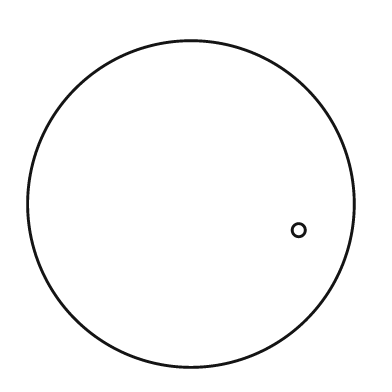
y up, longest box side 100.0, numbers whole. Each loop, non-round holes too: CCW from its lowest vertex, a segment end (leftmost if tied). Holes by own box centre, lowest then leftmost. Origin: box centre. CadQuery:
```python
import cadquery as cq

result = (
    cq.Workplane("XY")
    .moveTo(0.0, 0.0)
    .circle(50.0)
    .moveTo(33.0, -8.0)
    .circle(2.0)
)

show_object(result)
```